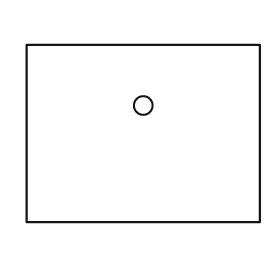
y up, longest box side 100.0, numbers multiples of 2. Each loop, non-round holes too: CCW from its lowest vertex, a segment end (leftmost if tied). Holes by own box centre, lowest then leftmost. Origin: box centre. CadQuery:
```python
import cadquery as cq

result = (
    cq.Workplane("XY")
    .moveTo(-50.0, -38.0)
    .lineTo(50.0, -38.0)
    .lineTo(50.0, 38.0)
    .lineTo(-50.0, 38.0)
    .close()
    .moveTo(0.0, 12.0)
    .circle(4.0)
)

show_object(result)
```